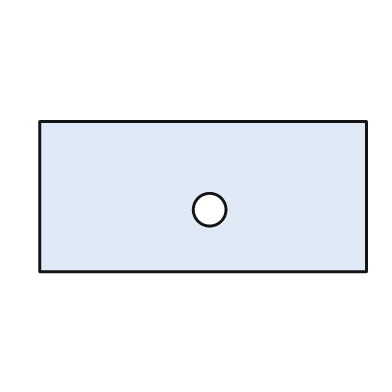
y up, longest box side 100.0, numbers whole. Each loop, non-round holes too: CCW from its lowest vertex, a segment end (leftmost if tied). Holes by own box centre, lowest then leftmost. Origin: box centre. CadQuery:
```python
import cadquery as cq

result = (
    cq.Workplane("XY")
    .moveTo(-50.0, -23.0)
    .lineTo(50.0, -23.0)
    .lineTo(50.0, 23.0)
    .lineTo(-50.0, 23.0)
    .close()
    .moveTo(2.0, -4.0)
    .circle(5.0)
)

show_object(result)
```